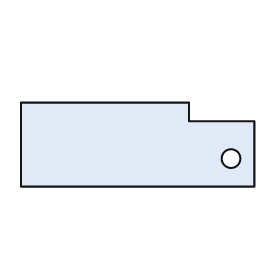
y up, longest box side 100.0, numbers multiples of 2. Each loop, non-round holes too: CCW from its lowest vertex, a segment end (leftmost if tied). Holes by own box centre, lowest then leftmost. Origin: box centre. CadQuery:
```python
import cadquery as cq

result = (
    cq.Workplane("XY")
    .moveTo(-50.0, -18.0)
    .lineTo(50.0, -18.0)
    .lineTo(50.0, 10.0)
    .lineTo(22.0, 10.0)
    .lineTo(22.0, 18.0)
    .lineTo(-50.0, 18.0)
    .close()
    .moveTo(40.0, -6.0)
    .circle(4.0)
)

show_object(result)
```